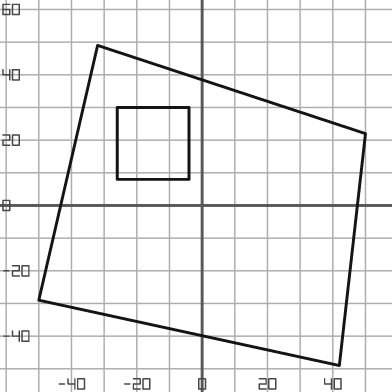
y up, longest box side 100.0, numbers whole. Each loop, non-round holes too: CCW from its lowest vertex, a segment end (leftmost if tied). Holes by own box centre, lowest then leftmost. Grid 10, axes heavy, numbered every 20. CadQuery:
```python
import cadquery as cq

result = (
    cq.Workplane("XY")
    .moveTo(42.0, -49.0)
    .lineTo(50.0, 22.0)
    .lineTo(-32.0, 49.0)
    .lineTo(-50.0, -29.0)
    .close()
    .moveTo(-26.0, 8.0)
    .lineTo(-4.0, 8.0)
    .lineTo(-4.0, 30.0)
    .lineTo(-26.0, 30.0)
    .close()
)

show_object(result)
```